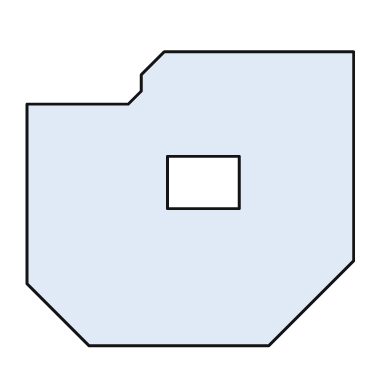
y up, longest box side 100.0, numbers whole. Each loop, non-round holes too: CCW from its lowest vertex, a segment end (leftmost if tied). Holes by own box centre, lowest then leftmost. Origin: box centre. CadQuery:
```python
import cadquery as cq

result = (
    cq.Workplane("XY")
    .moveTo(-31.0, -45.0)
    .lineTo(24.0, -45.0)
    .lineTo(50.0, -19.0)
    .lineTo(50.0, 45.0)
    .lineTo(-8.0, 45.0)
    .lineTo(-15.0, 38.0)
    .lineTo(-15.0, 33.0)
    .lineTo(-19.0, 29.0)
    .lineTo(-50.0, 29.0)
    .lineTo(-50.0, -26.0)
    .close()
    .moveTo(-7.0, -3.0)
    .lineTo(15.0, -3.0)
    .lineTo(15.0, 13.0)
    .lineTo(-7.0, 13.0)
    .close()
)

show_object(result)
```